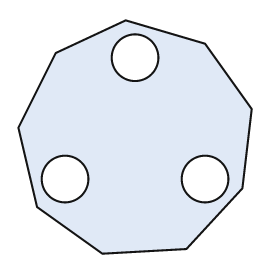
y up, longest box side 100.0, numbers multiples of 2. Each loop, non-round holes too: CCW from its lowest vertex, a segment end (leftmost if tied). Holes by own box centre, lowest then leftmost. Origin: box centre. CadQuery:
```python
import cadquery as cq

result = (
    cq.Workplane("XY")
    .moveTo(-14.0, -50.0)
    .lineTo(22.0, -48.0)
    .lineTo(46.0, -22.0)
    .lineTo(50.0, 12.0)
    .lineTo(30.0, 40.0)
    .lineTo(-4.0, 50.0)
    .lineTo(-34.0, 36.0)
    .lineTo(-50.0, 4.0)
    .lineTo(-42.0, -30.0)
    .close()
    .moveTo(-30.0, -18.0)
    .circle(10.0)
    .moveTo(30.0, -18.0)
    .circle(10.0)
    .moveTo(0.0, 34.0)
    .circle(10.0)
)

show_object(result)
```